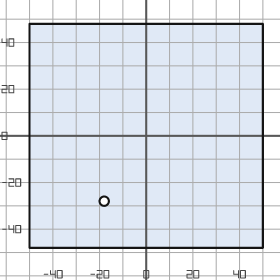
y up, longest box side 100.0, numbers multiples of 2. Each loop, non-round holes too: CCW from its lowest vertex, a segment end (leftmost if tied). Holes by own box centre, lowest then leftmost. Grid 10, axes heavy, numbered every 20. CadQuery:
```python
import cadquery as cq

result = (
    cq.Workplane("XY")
    .moveTo(-50.0, -48.0)
    .lineTo(50.0, -48.0)
    .lineTo(50.0, 48.0)
    .lineTo(-50.0, 48.0)
    .close()
    .moveTo(-18.0, -28.0)
    .circle(2.0)
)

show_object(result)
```